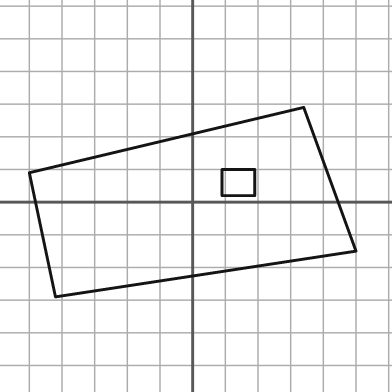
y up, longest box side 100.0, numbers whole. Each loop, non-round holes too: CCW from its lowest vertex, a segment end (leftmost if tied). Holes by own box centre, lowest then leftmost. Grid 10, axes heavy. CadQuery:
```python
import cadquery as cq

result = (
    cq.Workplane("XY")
    .moveTo(-42.0, -29.0)
    .lineTo(50.0, -15.0)
    .lineTo(34.0, 29.0)
    .lineTo(-50.0, 9.0)
    .close()
    .moveTo(9.0, 2.0)
    .lineTo(19.0, 2.0)
    .lineTo(19.0, 10.0)
    .lineTo(9.0, 10.0)
    .close()
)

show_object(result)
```